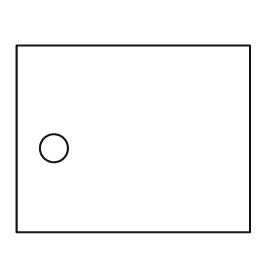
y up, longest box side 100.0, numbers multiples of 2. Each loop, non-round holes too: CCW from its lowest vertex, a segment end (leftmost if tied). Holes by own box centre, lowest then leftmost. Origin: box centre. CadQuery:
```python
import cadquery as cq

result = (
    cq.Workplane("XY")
    .moveTo(-50.0, -40.0)
    .lineTo(50.0, -40.0)
    .lineTo(50.0, 40.0)
    .lineTo(-50.0, 40.0)
    .close()
    .moveTo(-34.0, -4.0)
    .circle(6.0)
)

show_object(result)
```